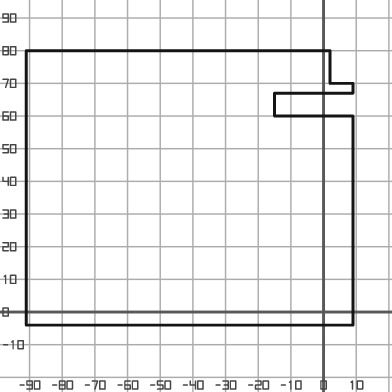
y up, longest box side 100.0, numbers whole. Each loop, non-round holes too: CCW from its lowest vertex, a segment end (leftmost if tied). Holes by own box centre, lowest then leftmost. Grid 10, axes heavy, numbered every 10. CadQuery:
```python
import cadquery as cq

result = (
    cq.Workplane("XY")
    .moveTo(-91.0, -4.0)
    .lineTo(9.0, -4.0)
    .lineTo(9.0, 60.0)
    .lineTo(-15.0, 60.0)
    .lineTo(-15.0, 67.0)
    .lineTo(9.0, 67.0)
    .lineTo(9.0, 70.0)
    .lineTo(2.0, 70.0)
    .lineTo(2.0, 80.0)
    .lineTo(-91.0, 80.0)
    .close()
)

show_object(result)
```